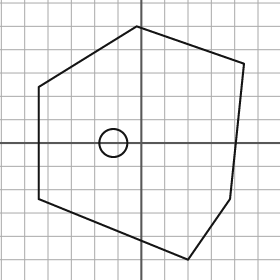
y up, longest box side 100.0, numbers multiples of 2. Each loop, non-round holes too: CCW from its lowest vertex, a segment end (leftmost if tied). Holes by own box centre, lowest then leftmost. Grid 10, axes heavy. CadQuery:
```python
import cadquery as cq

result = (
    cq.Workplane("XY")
    .moveTo(20.0, -50.0)
    .lineTo(38.0, -24.0)
    .lineTo(44.0, 34.0)
    .lineTo(-2.0, 50.0)
    .lineTo(-44.0, 24.0)
    .lineTo(-44.0, -24.0)
    .close()
    .moveTo(-12.0, 0.0)
    .circle(6.0)
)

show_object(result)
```